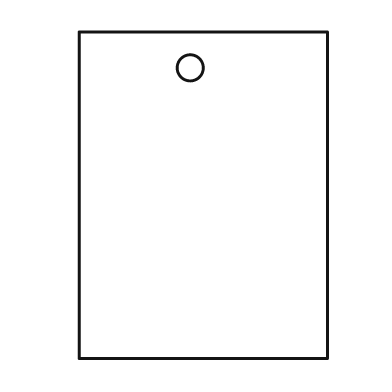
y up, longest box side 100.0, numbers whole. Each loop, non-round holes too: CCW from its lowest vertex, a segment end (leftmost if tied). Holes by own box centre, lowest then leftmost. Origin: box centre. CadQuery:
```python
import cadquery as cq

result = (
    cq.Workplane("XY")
    .moveTo(-38.0, -50.0)
    .lineTo(38.0, -50.0)
    .lineTo(38.0, 50.0)
    .lineTo(-38.0, 50.0)
    .close()
    .moveTo(-4.0, 39.0)
    .circle(4.0)
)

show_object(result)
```